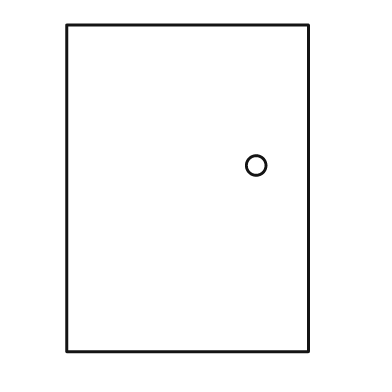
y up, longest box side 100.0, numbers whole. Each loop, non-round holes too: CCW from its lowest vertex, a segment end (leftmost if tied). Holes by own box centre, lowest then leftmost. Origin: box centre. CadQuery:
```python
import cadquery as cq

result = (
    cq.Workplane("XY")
    .moveTo(-37.0, -50.0)
    .lineTo(37.0, -50.0)
    .lineTo(37.0, 50.0)
    .lineTo(-37.0, 50.0)
    .close()
    .moveTo(21.0, 7.0)
    .circle(3.0)
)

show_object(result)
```